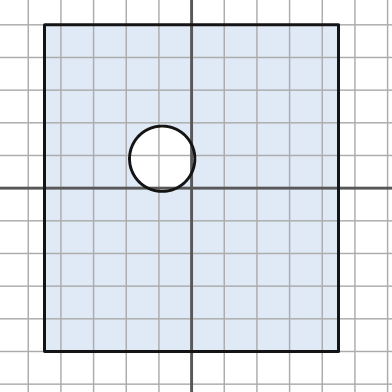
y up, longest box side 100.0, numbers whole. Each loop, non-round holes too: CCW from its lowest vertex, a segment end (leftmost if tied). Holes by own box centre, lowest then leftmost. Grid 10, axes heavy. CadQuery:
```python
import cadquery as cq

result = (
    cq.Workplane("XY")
    .moveTo(-45.0, -50.0)
    .lineTo(45.0, -50.0)
    .lineTo(45.0, 50.0)
    .lineTo(-45.0, 50.0)
    .close()
    .moveTo(-9.0, 9.0)
    .circle(10.0)
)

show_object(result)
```